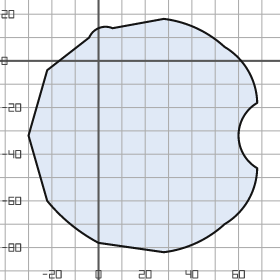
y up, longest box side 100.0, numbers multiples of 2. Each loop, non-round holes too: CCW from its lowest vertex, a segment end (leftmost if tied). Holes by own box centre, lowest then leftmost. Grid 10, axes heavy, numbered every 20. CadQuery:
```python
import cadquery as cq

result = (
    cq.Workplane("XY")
    .moveTo(28.0, -82.0)
    .threePointArc((42.0, -78.0), (54.0, -70.0))
    .threePointArc((64.0, -60.0), (68.0, -46.0))
    .threePointArc((60.0, -32.0), (68.0, -18.0))
    .threePointArc((64.0, -4.0), (54.0, 6.0))
    .threePointArc((42.0, 14.0), (28.0, 18.0))
    .lineTo(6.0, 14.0)
    .threePointArc((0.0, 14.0), (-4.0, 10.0))
    .lineTo(-22.0, -4.0)
    .lineTo(-30.0, -32.0)
    .lineTo(-22.0, -60.0)
    .threePointArc((-12.0, -70.0), (0.0, -78.0))
    .close()
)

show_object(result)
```